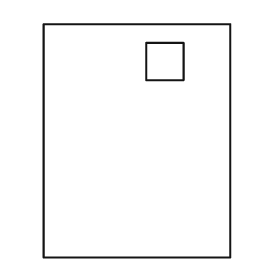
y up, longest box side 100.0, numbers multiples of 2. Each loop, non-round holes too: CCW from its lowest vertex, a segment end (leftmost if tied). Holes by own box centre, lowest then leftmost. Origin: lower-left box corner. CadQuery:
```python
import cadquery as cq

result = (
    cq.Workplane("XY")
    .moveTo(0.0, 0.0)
    .lineTo(80.0, 0.0)
    .lineTo(80.0, 100.0)
    .lineTo(0.0, 100.0)
    .close()
    .moveTo(44.0, 76.0)
    .lineTo(60.0, 76.0)
    .lineTo(60.0, 92.0)
    .lineTo(44.0, 92.0)
    .close()
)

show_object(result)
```